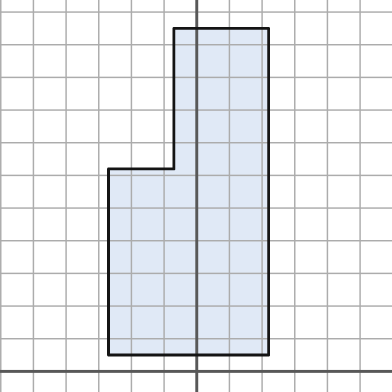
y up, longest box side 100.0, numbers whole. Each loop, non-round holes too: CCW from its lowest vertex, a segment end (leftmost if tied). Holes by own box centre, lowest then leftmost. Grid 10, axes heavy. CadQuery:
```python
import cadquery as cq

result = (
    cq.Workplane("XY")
    .moveTo(-27.0, 5.0)
    .lineTo(22.0, 5.0)
    .lineTo(22.0, 105.0)
    .lineTo(-7.0, 105.0)
    .lineTo(-7.0, 62.0)
    .lineTo(-27.0, 62.0)
    .close()
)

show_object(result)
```